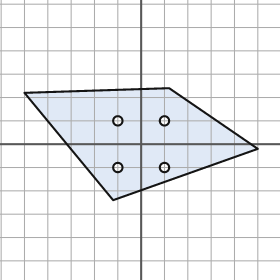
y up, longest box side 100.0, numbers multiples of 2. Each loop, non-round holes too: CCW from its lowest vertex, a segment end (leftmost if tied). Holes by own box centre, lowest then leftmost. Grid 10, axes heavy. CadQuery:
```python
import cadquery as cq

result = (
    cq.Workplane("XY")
    .moveTo(-12.0, -24.0)
    .lineTo(50.0, -2.0)
    .lineTo(12.0, 24.0)
    .lineTo(-50.0, 22.0)
    .close()
    .moveTo(-10.0, -10.0)
    .circle(2.0)
    .moveTo(10.0, -10.0)
    .circle(2.0)
    .moveTo(-10.0, 10.0)
    .circle(2.0)
    .moveTo(10.0, 10.0)
    .circle(2.0)
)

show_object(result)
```